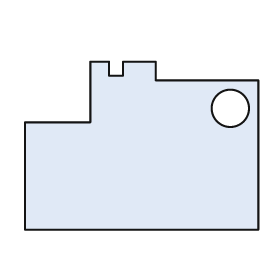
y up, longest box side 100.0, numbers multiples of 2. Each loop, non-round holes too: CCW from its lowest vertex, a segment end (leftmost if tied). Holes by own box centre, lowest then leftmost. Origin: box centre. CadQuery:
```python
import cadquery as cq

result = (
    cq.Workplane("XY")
    .moveTo(-50.0, -36.0)
    .lineTo(50.0, -36.0)
    .lineTo(50.0, 28.0)
    .lineTo(6.0, 28.0)
    .lineTo(6.0, 36.0)
    .lineTo(-8.0, 36.0)
    .lineTo(-8.0, 30.0)
    .lineTo(-14.0, 30.0)
    .lineTo(-14.0, 36.0)
    .lineTo(-22.0, 36.0)
    .lineTo(-22.0, 10.0)
    .lineTo(-50.0, 10.0)
    .close()
    .moveTo(38.0, 16.0)
    .circle(8.0)
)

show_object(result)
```